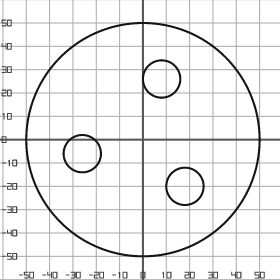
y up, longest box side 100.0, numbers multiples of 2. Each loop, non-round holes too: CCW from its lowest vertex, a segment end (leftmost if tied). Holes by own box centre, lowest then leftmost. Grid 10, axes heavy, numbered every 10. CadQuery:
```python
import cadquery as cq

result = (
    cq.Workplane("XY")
    .moveTo(0.0, 0.0)
    .circle(50.0)
    .moveTo(18.0, -20.0)
    .circle(8.0)
    .moveTo(-26.0, -6.0)
    .circle(8.0)
    .moveTo(8.0, 26.0)
    .circle(8.0)
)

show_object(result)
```